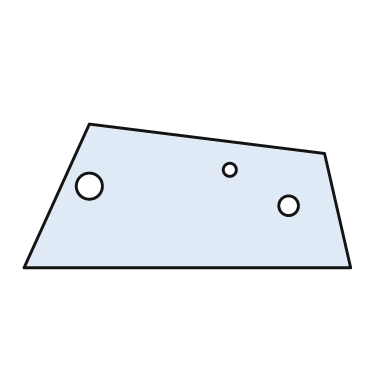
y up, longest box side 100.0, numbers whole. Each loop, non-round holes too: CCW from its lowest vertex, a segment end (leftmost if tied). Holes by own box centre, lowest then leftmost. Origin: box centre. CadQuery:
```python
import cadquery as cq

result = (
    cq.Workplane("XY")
    .moveTo(-50.0, -22.0)
    .lineTo(50.0, -22.0)
    .lineTo(42.0, 13.0)
    .lineTo(-30.0, 22.0)
    .close()
    .moveTo(31.0, -3.0)
    .circle(3.0)
    .moveTo(-30.0, 3.0)
    .circle(4.0)
    .moveTo(13.0, 8.0)
    .circle(2.0)
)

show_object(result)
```